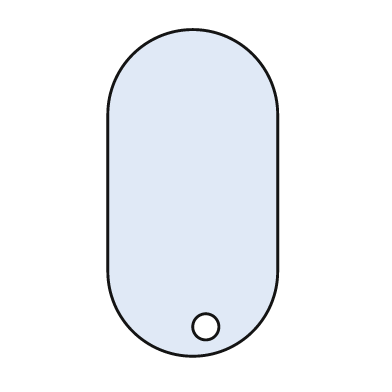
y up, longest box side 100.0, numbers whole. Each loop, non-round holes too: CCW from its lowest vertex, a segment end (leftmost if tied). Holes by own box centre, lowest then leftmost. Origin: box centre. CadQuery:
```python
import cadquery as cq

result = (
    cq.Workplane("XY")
    .moveTo(-26.0, -24.0)
    .threePointArc((0.0, -50.0), (26.0, -24.0))
    .lineTo(26.0, 24.0)
    .threePointArc((0.0, 50.0), (-26.0, 24.0))
    .close()
    .moveTo(4.0, -41.0)
    .circle(4.0)
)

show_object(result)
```